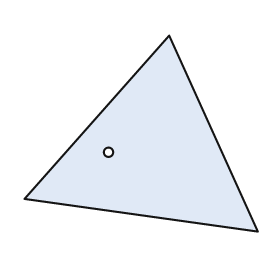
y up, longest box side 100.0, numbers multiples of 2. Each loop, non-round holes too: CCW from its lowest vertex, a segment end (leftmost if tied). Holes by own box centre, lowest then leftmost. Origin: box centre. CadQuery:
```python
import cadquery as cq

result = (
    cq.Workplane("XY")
    .moveTo(50.0, -42.0)
    .lineTo(12.0, 42.0)
    .lineTo(-50.0, -28.0)
    .close()
    .moveTo(-14.0, -8.0)
    .circle(2.0)
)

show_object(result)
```